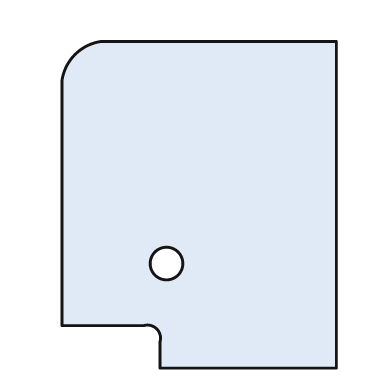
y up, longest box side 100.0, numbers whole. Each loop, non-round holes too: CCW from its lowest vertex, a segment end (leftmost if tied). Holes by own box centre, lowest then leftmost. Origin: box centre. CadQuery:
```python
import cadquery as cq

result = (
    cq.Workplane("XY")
    .moveTo(-12.0, -50.0)
    .lineTo(42.0, -50.0)
    .lineTo(42.0, 50.0)
    .lineTo(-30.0, 50.0)
    .threePointArc((-38.0, 46.0), (-42.0, 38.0))
    .lineTo(-42.0, -37.0)
    .lineTo(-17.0, -37.0)
    .threePointArc((-13.0, -38.0), (-12.0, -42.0))
    .close()
    .moveTo(-10.0, -18.0)
    .circle(5.0)
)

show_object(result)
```